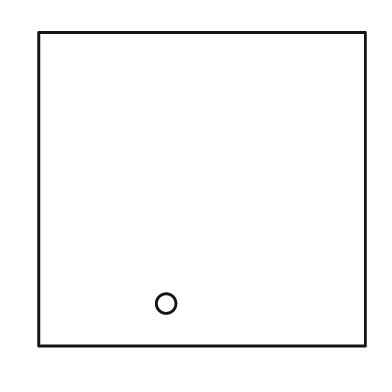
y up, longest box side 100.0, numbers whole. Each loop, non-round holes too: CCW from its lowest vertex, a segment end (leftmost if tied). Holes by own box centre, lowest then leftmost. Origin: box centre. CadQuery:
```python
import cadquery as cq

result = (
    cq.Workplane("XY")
    .moveTo(-50.0, -48.0)
    .lineTo(50.0, -48.0)
    .lineTo(50.0, 48.0)
    .lineTo(-50.0, 48.0)
    .close()
    .moveTo(-11.0, -35.0)
    .circle(3.0)
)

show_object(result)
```